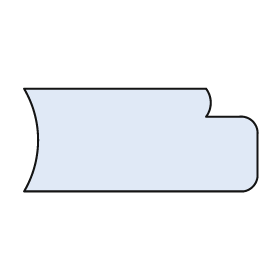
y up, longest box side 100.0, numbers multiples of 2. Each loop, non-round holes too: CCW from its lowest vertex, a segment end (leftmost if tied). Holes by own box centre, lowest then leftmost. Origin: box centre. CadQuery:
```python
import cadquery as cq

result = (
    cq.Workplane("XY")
    .moveTo(-50.0, -22.0)
    .lineTo(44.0, -22.0)
    .threePointArc((48.0, -20.0), (50.0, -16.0))
    .lineTo(50.0, 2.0)
    .threePointArc((48.0, 8.0), (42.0, 10.0))
    .lineTo(28.0, 10.0)
    .threePointArc((30.0, 16.0), (28.0, 22.0))
    .lineTo(-50.0, 22.0)
    .threePointArc((-44.0, 0.0), (-50.0, -22.0))
    .close()
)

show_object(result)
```